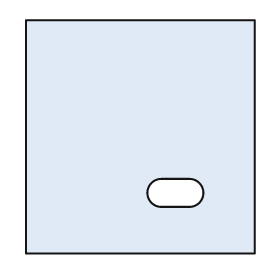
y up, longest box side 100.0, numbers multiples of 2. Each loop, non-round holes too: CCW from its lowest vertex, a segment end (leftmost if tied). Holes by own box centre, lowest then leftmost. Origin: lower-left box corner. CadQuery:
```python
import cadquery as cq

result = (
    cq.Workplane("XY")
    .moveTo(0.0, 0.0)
    .lineTo(98.0, 0.0)
    .lineTo(98.0, 100.0)
    .lineTo(0.0, 100.0)
    .close()
    .moveTo(58.0, 20.0)
    .lineTo(70.0, 20.0)
    .threePointArc((76.0, 26.0), (70.0, 32.0))
    .lineTo(58.0, 32.0)
    .threePointArc((52.0, 26.0), (58.0, 20.0))
    .close()
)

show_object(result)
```